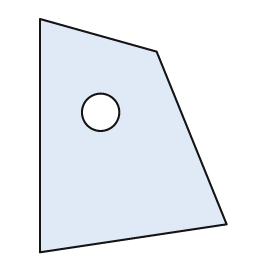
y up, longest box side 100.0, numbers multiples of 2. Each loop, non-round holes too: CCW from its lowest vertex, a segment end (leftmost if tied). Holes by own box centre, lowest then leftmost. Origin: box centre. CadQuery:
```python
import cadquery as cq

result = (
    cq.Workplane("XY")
    .moveTo(-40.0, -50.0)
    .lineTo(40.0, -38.0)
    .lineTo(10.0, 36.0)
    .lineTo(-40.0, 50.0)
    .close()
    .moveTo(-14.0, 10.0)
    .circle(8.0)
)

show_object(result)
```